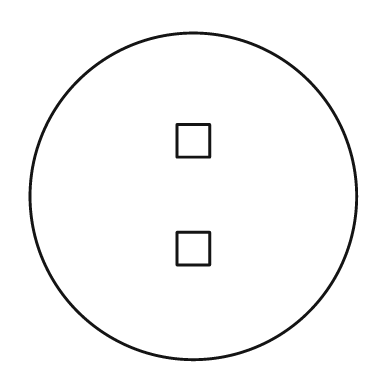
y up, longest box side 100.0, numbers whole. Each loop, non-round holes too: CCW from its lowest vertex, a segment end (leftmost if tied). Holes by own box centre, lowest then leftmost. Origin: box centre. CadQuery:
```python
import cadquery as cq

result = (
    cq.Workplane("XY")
    .moveTo(0.0, 0.0)
    .circle(50.0)
    .moveTo(-5.0, -21.0)
    .lineTo(5.0, -21.0)
    .lineTo(5.0, -11.0)
    .lineTo(-5.0, -11.0)
    .close()
    .moveTo(-5.0, 12.0)
    .lineTo(5.0, 12.0)
    .lineTo(5.0, 22.0)
    .lineTo(-5.0, 22.0)
    .close()
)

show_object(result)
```